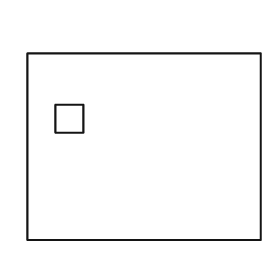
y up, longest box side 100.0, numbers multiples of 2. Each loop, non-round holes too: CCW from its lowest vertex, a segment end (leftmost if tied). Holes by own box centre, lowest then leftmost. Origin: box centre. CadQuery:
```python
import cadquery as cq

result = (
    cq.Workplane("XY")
    .moveTo(-50.0, -40.0)
    .lineTo(50.0, -40.0)
    .lineTo(50.0, 40.0)
    .lineTo(-50.0, 40.0)
    .close()
    .moveTo(-38.0, 6.0)
    .lineTo(-26.0, 6.0)
    .lineTo(-26.0, 18.0)
    .lineTo(-38.0, 18.0)
    .close()
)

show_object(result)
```